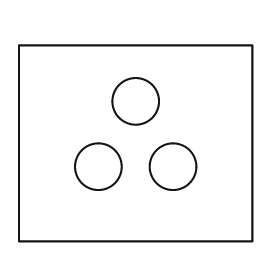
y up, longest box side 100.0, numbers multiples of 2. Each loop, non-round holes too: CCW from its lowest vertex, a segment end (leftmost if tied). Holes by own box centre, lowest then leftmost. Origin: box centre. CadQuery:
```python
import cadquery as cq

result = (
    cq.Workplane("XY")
    .moveTo(-50.0, -42.0)
    .lineTo(50.0, -42.0)
    .lineTo(50.0, 42.0)
    .lineTo(-50.0, 42.0)
    .close()
    .moveTo(-16.0, -10.0)
    .circle(10.0)
    .moveTo(16.0, -10.0)
    .circle(10.0)
    .moveTo(0.0, 18.0)
    .circle(10.0)
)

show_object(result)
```